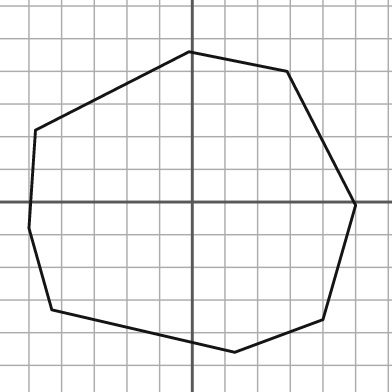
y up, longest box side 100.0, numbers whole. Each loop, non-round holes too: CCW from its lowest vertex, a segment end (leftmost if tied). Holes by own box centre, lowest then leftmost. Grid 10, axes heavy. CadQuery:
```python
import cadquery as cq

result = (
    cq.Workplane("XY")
    .moveTo(13.0, -46.0)
    .lineTo(40.0, -36.0)
    .lineTo(50.0, -1.0)
    .lineTo(29.0, 40.0)
    .lineTo(-1.0, 46.0)
    .lineTo(-48.0, 22.0)
    .lineTo(-50.0, -8.0)
    .lineTo(-43.0, -33.0)
    .close()
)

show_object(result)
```